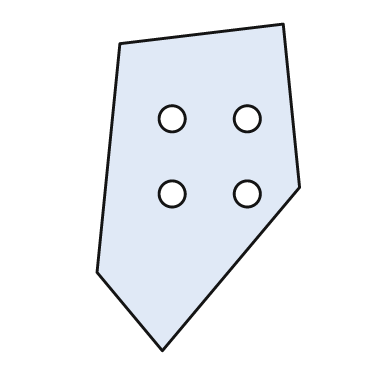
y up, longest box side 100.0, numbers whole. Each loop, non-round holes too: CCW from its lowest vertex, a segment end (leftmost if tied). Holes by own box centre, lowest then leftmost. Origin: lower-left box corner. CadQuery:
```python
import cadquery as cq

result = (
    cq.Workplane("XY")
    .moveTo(20.0, 0.0)
    .lineTo(62.0, 50.0)
    .lineTo(57.0, 100.0)
    .lineTo(7.0, 94.0)
    .lineTo(0.0, 24.0)
    .close()
    .moveTo(23.0, 48.0)
    .circle(4.0)
    .moveTo(46.0, 48.0)
    .circle(4.0)
    .moveTo(23.0, 71.0)
    .circle(4.0)
    .moveTo(46.0, 71.0)
    .circle(4.0)
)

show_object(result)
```